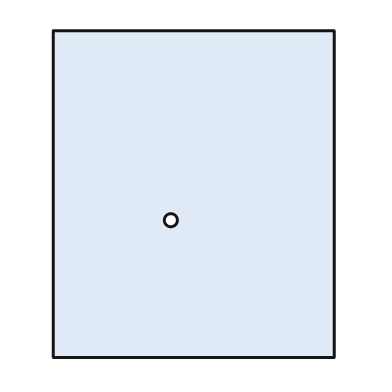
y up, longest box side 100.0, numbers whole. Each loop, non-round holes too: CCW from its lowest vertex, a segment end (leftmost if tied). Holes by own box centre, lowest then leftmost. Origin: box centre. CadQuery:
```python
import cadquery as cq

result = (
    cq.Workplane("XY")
    .moveTo(-43.0, -50.0)
    .lineTo(43.0, -50.0)
    .lineTo(43.0, 50.0)
    .lineTo(-43.0, 50.0)
    .close()
    .moveTo(-7.0, -8.0)
    .circle(2.0)
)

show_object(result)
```